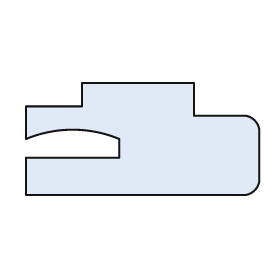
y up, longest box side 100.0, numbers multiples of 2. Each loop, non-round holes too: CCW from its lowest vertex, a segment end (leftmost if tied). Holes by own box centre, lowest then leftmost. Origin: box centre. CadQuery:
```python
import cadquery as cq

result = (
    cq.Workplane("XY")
    .moveTo(-50.0, -24.0)
    .lineTo(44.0, -24.0)
    .threePointArc((48.0, -22.0), (50.0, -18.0))
    .lineTo(50.0, 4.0)
    .threePointArc((48.0, 8.0), (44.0, 10.0))
    .lineTo(22.0, 10.0)
    .lineTo(22.0, 24.0)
    .lineTo(-26.0, 24.0)
    .lineTo(-26.0, 14.0)
    .lineTo(-50.0, 14.0)
    .lineTo(-50.0, 0.0)
    .threePointArc((-30.0, 4.0), (-10.0, 0.0))
    .lineTo(-10.0, -8.0)
    .lineTo(-50.0, -8.0)
    .close()
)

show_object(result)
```